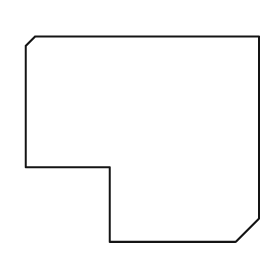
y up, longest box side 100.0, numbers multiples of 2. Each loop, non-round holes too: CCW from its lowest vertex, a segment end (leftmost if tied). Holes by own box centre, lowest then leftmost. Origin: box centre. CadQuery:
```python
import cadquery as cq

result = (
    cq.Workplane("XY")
    .moveTo(-14.0, -44.0)
    .lineTo(40.0, -44.0)
    .lineTo(50.0, -34.0)
    .lineTo(50.0, 44.0)
    .lineTo(-46.0, 44.0)
    .lineTo(-50.0, 40.0)
    .lineTo(-50.0, -12.0)
    .lineTo(-14.0, -12.0)
    .close()
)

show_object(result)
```